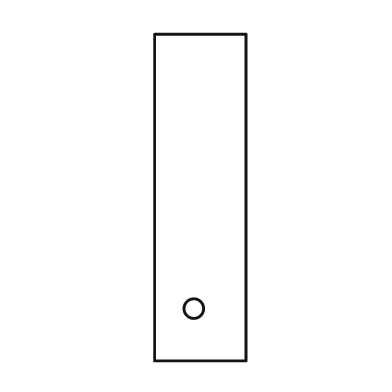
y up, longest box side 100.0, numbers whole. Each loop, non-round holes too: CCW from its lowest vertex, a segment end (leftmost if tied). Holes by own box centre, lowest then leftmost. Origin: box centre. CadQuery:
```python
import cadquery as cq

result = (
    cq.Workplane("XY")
    .moveTo(-14.0, -50.0)
    .lineTo(14.0, -50.0)
    .lineTo(14.0, 50.0)
    .lineTo(-14.0, 50.0)
    .close()
    .moveTo(-2.0, -34.0)
    .circle(3.0)
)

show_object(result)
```